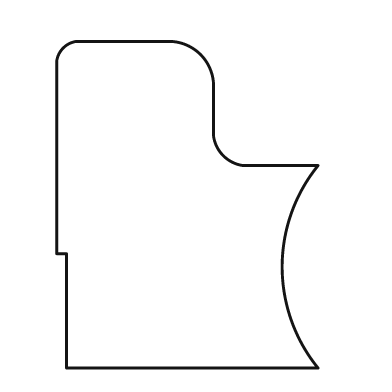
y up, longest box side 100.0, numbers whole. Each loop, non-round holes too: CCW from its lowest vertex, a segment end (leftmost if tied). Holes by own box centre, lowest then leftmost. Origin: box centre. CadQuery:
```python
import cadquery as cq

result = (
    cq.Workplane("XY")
    .moveTo(-37.0, -50.0)
    .lineTo(40.0, -50.0)
    .threePointArc((29.0, -19.0), (40.0, 12.0))
    .lineTo(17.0, 12.0)
    .threePointArc((11.0, 15.0), (8.0, 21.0))
    .lineTo(8.0, 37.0)
    .threePointArc((4.0, 46.0), (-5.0, 50.0))
    .lineTo(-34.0, 50.0)
    .threePointArc((-38.0, 48.0), (-40.0, 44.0))
    .lineTo(-40.0, -15.0)
    .lineTo(-37.0, -15.0)
    .close()
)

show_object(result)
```